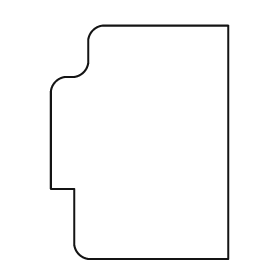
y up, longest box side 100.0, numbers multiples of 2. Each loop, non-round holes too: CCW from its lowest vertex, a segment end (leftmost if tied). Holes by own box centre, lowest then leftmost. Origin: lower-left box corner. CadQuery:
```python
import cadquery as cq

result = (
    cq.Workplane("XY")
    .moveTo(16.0, 0.0)
    .lineTo(76.0, 0.0)
    .lineTo(76.0, 100.0)
    .lineTo(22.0, 100.0)
    .threePointArc((18.0, 98.0), (16.0, 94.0))
    .lineTo(16.0, 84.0)
    .threePointArc((14.0, 80.0), (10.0, 78.0))
    .lineTo(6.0, 78.0)
    .threePointArc((2.0, 76.0), (0.0, 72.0))
    .lineTo(0.0, 30.0)
    .lineTo(10.0, 30.0)
    .lineTo(10.0, 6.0)
    .threePointArc((12.0, 2.0), (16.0, 0.0))
    .close()
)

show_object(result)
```